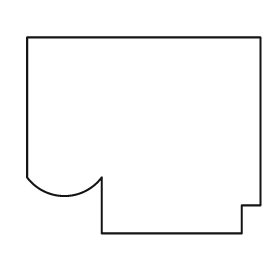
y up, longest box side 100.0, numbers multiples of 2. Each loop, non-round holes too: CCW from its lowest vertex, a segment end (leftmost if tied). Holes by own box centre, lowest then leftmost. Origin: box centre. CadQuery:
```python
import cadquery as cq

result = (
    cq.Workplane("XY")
    .moveTo(-18.0, -42.0)
    .lineTo(42.0, -42.0)
    .lineTo(42.0, -30.0)
    .lineTo(50.0, -30.0)
    .lineTo(50.0, 42.0)
    .lineTo(-50.0, 42.0)
    .lineTo(-50.0, -18.0)
    .threePointArc((-34.0, -26.0), (-18.0, -18.0))
    .close()
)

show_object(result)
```